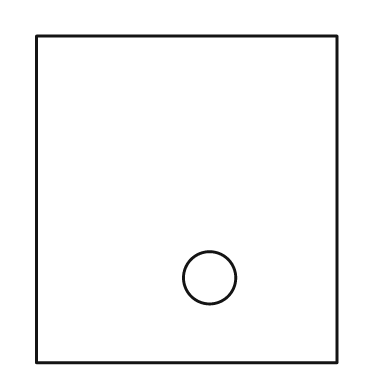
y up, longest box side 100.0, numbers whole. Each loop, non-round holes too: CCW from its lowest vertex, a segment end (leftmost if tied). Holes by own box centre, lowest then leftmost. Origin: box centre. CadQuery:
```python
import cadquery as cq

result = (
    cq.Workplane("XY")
    .moveTo(-46.0, -50.0)
    .lineTo(46.0, -50.0)
    .lineTo(46.0, 50.0)
    .lineTo(-46.0, 50.0)
    .close()
    .moveTo(7.0, -24.0)
    .circle(8.0)
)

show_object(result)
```